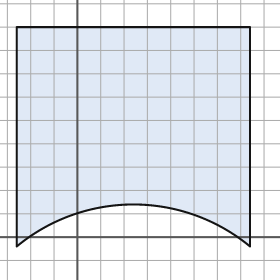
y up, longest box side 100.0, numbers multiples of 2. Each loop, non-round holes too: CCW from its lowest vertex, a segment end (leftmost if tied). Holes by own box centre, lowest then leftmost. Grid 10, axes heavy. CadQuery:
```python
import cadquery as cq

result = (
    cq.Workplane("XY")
    .moveTo(-26.0, -4.0)
    .threePointArc((24.0, 14.0), (74.0, -4.0))
    .lineTo(74.0, 90.0)
    .lineTo(-26.0, 90.0)
    .close()
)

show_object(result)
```